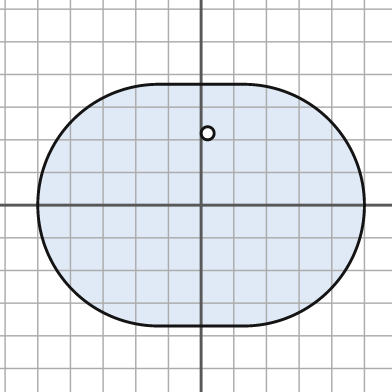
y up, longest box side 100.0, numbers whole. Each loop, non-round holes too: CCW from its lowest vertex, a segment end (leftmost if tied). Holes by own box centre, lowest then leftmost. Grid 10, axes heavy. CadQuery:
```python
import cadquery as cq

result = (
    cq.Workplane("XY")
    .moveTo(-13.0, -37.0)
    .lineTo(13.0, -37.0)
    .threePointArc((50.0, 0.0), (13.0, 37.0))
    .lineTo(-13.0, 37.0)
    .threePointArc((-50.0, 0.0), (-13.0, -37.0))
    .close()
    .moveTo(2.0, 22.0)
    .circle(2.0)
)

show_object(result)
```